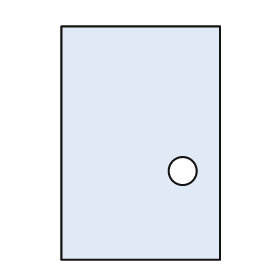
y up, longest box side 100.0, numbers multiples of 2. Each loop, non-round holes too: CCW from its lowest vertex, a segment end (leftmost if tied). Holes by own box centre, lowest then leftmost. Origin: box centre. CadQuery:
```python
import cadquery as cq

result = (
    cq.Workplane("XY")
    .moveTo(-34.0, -50.0)
    .lineTo(34.0, -50.0)
    .lineTo(34.0, 50.0)
    .lineTo(-34.0, 50.0)
    .close()
    .moveTo(18.0, -12.0)
    .circle(6.0)
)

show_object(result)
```